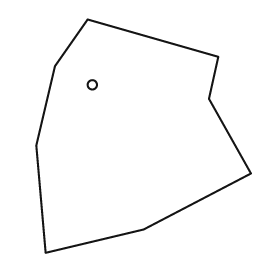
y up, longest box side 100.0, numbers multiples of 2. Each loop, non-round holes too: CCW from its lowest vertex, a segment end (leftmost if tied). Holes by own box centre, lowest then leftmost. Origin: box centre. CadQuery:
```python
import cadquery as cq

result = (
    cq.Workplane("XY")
    .moveTo(-42.0, -50.0)
    .lineTo(0.0, -40.0)
    .lineTo(46.0, -16.0)
    .lineTo(28.0, 16.0)
    .lineTo(32.0, 34.0)
    .lineTo(-24.0, 50.0)
    .lineTo(-38.0, 30.0)
    .lineTo(-46.0, -4.0)
    .close()
    .moveTo(-22.0, 22.0)
    .circle(2.0)
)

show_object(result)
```